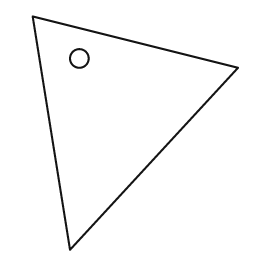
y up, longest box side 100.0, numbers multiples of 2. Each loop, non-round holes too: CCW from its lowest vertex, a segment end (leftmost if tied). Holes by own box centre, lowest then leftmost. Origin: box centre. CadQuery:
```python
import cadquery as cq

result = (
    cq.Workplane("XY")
    .moveTo(-28.0, -50.0)
    .lineTo(44.0, 28.0)
    .lineTo(-44.0, 50.0)
    .close()
    .moveTo(-24.0, 32.0)
    .circle(4.0)
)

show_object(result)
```